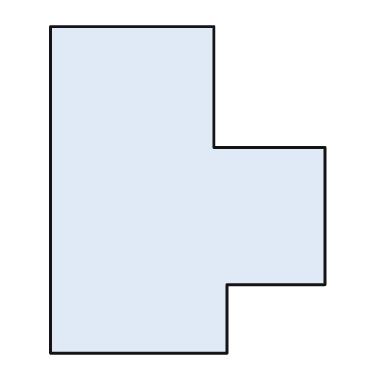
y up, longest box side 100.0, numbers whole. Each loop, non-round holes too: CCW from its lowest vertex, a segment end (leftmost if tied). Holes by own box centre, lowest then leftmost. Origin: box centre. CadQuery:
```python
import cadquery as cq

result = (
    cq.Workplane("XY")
    .moveTo(-42.0, -50.0)
    .lineTo(12.0, -50.0)
    .lineTo(12.0, -29.0)
    .lineTo(42.0, -29.0)
    .lineTo(42.0, 13.0)
    .lineTo(8.0, 13.0)
    .lineTo(8.0, 50.0)
    .lineTo(-42.0, 50.0)
    .close()
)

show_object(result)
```